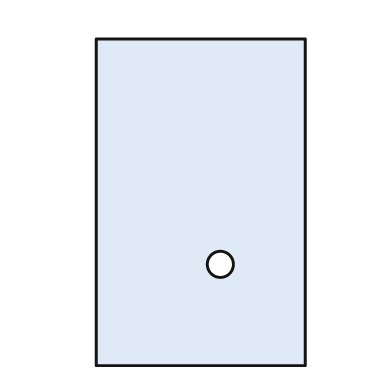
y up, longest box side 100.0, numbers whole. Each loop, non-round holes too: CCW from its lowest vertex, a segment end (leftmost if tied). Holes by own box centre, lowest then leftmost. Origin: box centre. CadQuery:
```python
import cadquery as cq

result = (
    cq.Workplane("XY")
    .moveTo(-32.0, -50.0)
    .lineTo(32.0, -50.0)
    .lineTo(32.0, 50.0)
    .lineTo(-32.0, 50.0)
    .close()
    .moveTo(6.0, -19.0)
    .circle(4.0)
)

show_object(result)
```